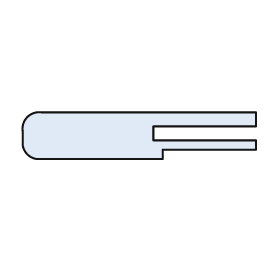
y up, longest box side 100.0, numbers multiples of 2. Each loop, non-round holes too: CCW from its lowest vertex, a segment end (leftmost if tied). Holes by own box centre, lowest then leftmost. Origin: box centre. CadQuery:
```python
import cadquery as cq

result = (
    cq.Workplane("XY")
    .moveTo(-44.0, -10.0)
    .lineTo(10.0, -10.0)
    .lineTo(10.0, -6.0)
    .lineTo(50.0, -6.0)
    .lineTo(50.0, -2.0)
    .lineTo(6.0, -2.0)
    .lineTo(6.0, 4.0)
    .lineTo(50.0, 4.0)
    .lineTo(50.0, 10.0)
    .lineTo(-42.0, 10.0)
    .threePointArc((-48.0, 8.0), (-50.0, 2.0))
    .lineTo(-50.0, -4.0)
    .threePointArc((-48.0, -8.0), (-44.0, -10.0))
    .close()
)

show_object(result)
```